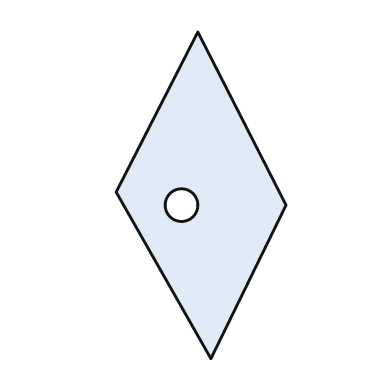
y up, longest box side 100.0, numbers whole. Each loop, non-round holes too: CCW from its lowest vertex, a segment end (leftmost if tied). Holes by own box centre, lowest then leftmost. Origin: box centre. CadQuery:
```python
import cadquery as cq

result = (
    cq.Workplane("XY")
    .moveTo(3.0, -50.0)
    .lineTo(26.0, -3.0)
    .lineTo(-1.0, 50.0)
    .lineTo(-26.0, 1.0)
    .close()
    .moveTo(-6.0, -3.0)
    .circle(5.0)
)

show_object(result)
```